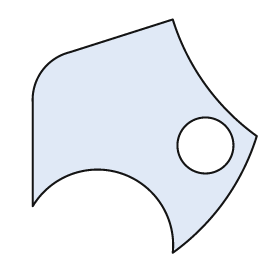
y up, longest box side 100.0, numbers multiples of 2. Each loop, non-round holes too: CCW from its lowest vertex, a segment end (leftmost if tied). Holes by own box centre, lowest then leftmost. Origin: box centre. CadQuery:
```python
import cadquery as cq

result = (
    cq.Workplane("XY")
    .moveTo(12.0, -50.0)
    .threePointArc((34.0, -28.0), (48.0, 0.0))
    .threePointArc((26.0, 22.0), (12.0, 50.0))
    .lineTo(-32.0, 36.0)
    .threePointArc((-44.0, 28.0), (-48.0, 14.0))
    .lineTo(-48.0, -30.0)
    .threePointArc((-10.0, -16.0), (12.0, -50.0))
    .close()
    .moveTo(26.0, -4.0)
    .circle(12.0)
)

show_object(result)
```